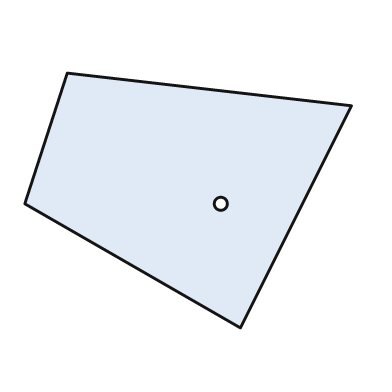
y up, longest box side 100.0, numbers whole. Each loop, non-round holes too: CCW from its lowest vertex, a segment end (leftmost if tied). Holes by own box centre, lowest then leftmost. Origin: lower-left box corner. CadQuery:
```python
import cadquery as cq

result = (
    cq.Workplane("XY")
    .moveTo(66.0, 0.0)
    .lineTo(100.0, 68.0)
    .lineTo(13.0, 78.0)
    .lineTo(0.0, 38.0)
    .close()
    .moveTo(60.0, 38.0)
    .circle(2.0)
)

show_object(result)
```